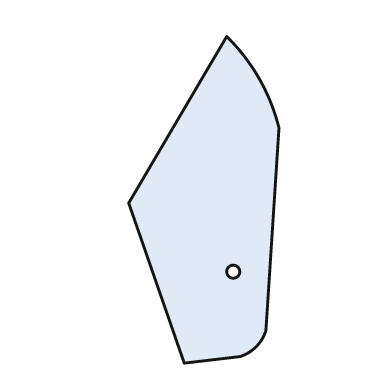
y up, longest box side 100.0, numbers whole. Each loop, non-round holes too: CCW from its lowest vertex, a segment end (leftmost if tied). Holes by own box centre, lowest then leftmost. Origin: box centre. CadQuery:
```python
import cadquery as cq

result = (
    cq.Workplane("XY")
    .moveTo(-6.0, -50.0)
    .lineTo(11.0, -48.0)
    .threePointArc((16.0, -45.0), (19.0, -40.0))
    .lineTo(23.0, 22.0)
    .threePointArc((17.0, 37.0), (7.0, 50.0))
    .lineTo(-23.0, -1.0)
    .close()
    .moveTo(9.0, -22.0)
    .circle(2.0)
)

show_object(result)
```